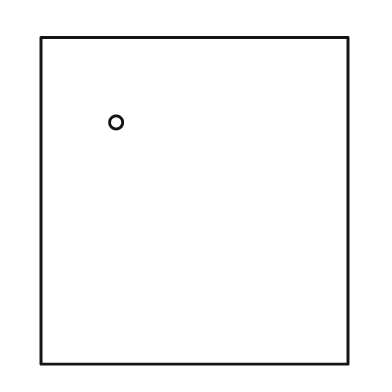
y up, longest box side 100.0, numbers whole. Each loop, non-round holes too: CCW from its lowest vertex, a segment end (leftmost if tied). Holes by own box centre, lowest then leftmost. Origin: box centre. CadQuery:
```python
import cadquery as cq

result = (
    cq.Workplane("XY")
    .moveTo(-47.0, -50.0)
    .lineTo(47.0, -50.0)
    .lineTo(47.0, 50.0)
    .lineTo(-47.0, 50.0)
    .close()
    .moveTo(-24.0, 24.0)
    .circle(2.0)
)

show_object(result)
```